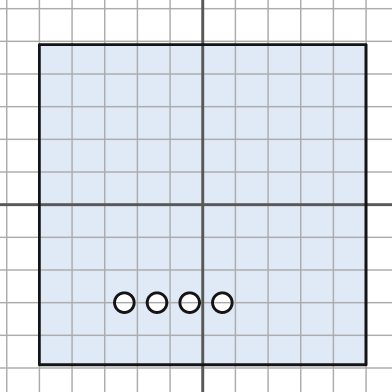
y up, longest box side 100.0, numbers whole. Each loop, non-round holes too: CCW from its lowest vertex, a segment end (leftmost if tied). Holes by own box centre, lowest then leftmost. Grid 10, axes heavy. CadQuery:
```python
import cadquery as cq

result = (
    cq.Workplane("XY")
    .moveTo(-50.0, -49.0)
    .lineTo(50.0, -49.0)
    .lineTo(50.0, 49.0)
    .lineTo(-50.0, 49.0)
    .close()
    .moveTo(-24.0, -30.0)
    .circle(3.0)
    .moveTo(-14.0, -30.0)
    .circle(3.0)
    .moveTo(-4.0, -30.0)
    .circle(3.0)
    .moveTo(6.0, -30.0)
    .circle(3.0)
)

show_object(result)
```